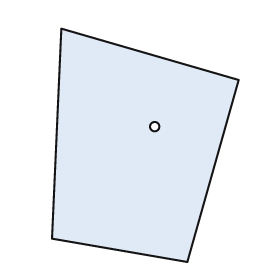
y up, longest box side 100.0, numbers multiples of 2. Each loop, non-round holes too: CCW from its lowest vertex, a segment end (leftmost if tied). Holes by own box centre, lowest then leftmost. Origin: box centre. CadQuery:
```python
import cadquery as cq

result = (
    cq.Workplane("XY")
    .moveTo(18.0, -50.0)
    .lineTo(40.0, 28.0)
    .lineTo(-36.0, 50.0)
    .lineTo(-40.0, -40.0)
    .close()
    .moveTo(4.0, 8.0)
    .circle(2.0)
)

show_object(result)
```